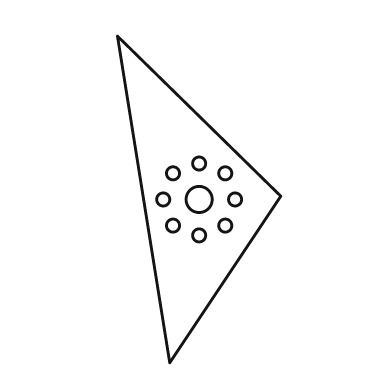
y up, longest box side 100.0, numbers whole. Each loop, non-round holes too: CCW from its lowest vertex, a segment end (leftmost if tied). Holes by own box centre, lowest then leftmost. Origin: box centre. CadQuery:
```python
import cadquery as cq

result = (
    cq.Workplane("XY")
    .moveTo(-9.0, -50.0)
    .lineTo(25.0, 1.0)
    .lineTo(-25.0, 50.0)
    .close()
    .moveTo(0.0, -11.0)
    .circle(2.0)
    .moveTo(-8.0, -8.0)
    .circle(2.0)
    .moveTo(8.0, -8.0)
    .circle(2.0)
    .moveTo(-11.0, 0.0)
    .circle(2.0)
    .moveTo(0.0, 0.0)
    .circle(4.0)
    .moveTo(11.0, 0.0)
    .circle(2.0)
    .moveTo(-8.0, 8.0)
    .circle(2.0)
    .moveTo(8.0, 8.0)
    .circle(2.0)
    .moveTo(0.0, 11.0)
    .circle(2.0)
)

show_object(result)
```